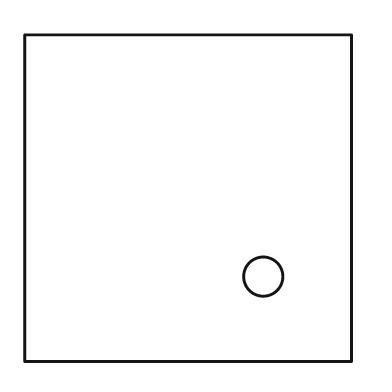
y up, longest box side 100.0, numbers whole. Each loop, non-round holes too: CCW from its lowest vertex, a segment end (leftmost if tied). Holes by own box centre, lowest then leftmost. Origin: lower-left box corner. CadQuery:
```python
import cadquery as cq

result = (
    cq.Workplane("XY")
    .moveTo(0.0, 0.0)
    .lineTo(100.0, 0.0)
    .lineTo(100.0, 100.0)
    .lineTo(0.0, 100.0)
    .close()
    .moveTo(73.0, 26.0)
    .circle(6.0)
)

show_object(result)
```